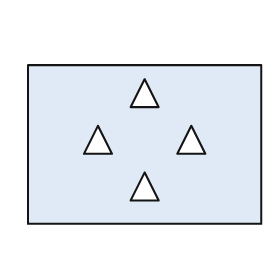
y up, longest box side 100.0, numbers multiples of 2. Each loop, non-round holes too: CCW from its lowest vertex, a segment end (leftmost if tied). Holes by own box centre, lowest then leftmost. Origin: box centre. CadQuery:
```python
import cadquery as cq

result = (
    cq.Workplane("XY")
    .moveTo(-50.0, -34.0)
    .lineTo(50.0, -34.0)
    .lineTo(50.0, 34.0)
    .lineTo(-50.0, 34.0)
    .close()
    .moveTo(-6.0, -24.0)
    .lineTo(6.0, -24.0)
    .lineTo(0.0, -12.0)
    .close()
    .moveTo(-26.0, -4.0)
    .lineTo(-14.0, -4.0)
    .lineTo(-20.0, 8.0)
    .close()
    .moveTo(14.0, -4.0)
    .lineTo(26.0, -4.0)
    .lineTo(20.0, 8.0)
    .close()
    .moveTo(-6.0, 16.0)
    .lineTo(6.0, 16.0)
    .lineTo(0.0, 28.0)
    .close()
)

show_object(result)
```